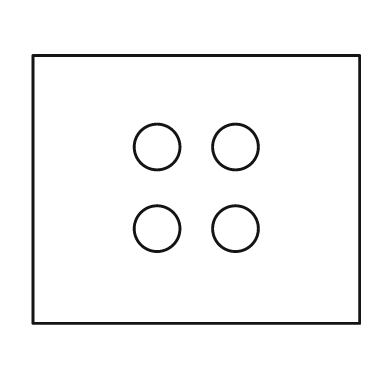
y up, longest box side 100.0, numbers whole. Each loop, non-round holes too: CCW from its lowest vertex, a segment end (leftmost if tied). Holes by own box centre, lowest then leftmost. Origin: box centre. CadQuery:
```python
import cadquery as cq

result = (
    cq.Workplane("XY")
    .moveTo(-50.0, -41.0)
    .lineTo(50.0, -41.0)
    .lineTo(50.0, 41.0)
    .lineTo(-50.0, 41.0)
    .close()
    .moveTo(-12.0, -12.0)
    .circle(7.0)
    .moveTo(12.0, -12.0)
    .circle(7.0)
    .moveTo(-12.0, 13.0)
    .circle(7.0)
    .moveTo(12.0, 13.0)
    .circle(7.0)
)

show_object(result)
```